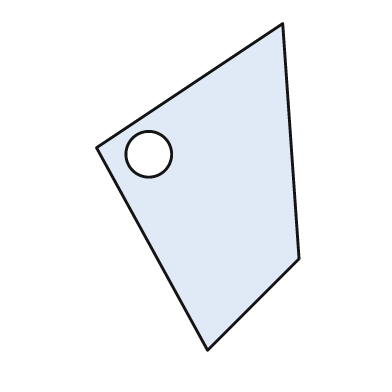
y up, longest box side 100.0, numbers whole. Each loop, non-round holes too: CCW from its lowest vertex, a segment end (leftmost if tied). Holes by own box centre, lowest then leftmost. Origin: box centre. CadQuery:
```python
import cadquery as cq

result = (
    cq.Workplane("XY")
    .moveTo(3.0, -50.0)
    .lineTo(31.0, -22.0)
    .lineTo(26.0, 50.0)
    .lineTo(-31.0, 12.0)
    .close()
    .moveTo(-15.0, 10.0)
    .circle(7.0)
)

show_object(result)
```